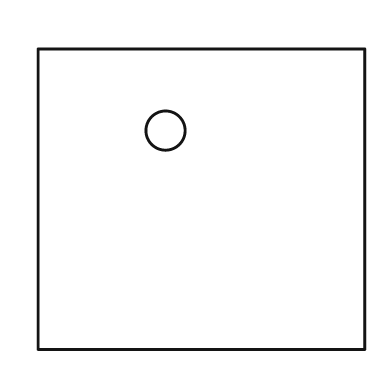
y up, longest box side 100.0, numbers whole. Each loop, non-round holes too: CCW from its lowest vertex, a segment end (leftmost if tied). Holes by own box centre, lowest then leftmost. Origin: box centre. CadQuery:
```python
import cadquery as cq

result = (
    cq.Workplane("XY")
    .moveTo(-50.0, -46.0)
    .lineTo(50.0, -46.0)
    .lineTo(50.0, 46.0)
    .lineTo(-50.0, 46.0)
    .close()
    .moveTo(-11.0, 21.0)
    .circle(6.0)
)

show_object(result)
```